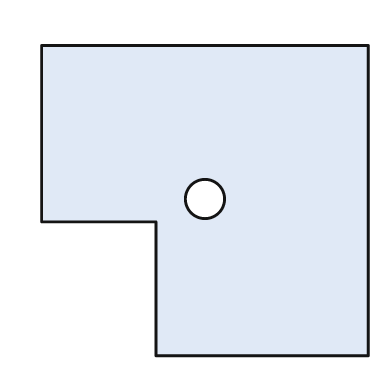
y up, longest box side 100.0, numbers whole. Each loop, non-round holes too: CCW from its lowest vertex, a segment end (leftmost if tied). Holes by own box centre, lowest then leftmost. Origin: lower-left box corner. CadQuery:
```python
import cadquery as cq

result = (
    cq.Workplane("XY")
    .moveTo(35.0, 0.0)
    .lineTo(100.0, 0.0)
    .lineTo(100.0, 95.0)
    .lineTo(0.0, 95.0)
    .lineTo(0.0, 41.0)
    .lineTo(35.0, 41.0)
    .close()
    .moveTo(50.0, 48.0)
    .circle(6.0)
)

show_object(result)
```